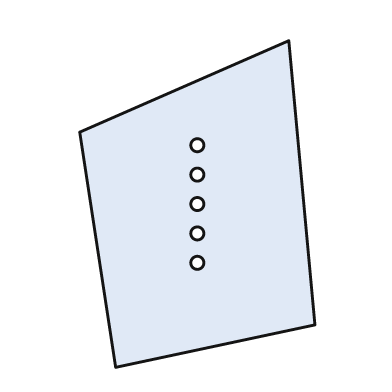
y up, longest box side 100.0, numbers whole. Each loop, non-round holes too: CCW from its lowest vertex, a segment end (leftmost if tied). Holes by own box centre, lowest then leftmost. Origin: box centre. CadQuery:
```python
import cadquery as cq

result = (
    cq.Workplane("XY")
    .moveTo(-25.0, -50.0)
    .lineTo(36.0, -37.0)
    .lineTo(28.0, 50.0)
    .lineTo(-36.0, 22.0)
    .close()
    .moveTo(0.0, -18.0)
    .circle(2.0)
    .moveTo(0.0, -9.0)
    .circle(2.0)
    .moveTo(0.0, 0.0)
    .circle(2.0)
    .moveTo(0.0, 9.0)
    .circle(2.0)
    .moveTo(0.0, 18.0)
    .circle(2.0)
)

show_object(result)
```